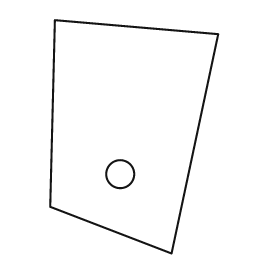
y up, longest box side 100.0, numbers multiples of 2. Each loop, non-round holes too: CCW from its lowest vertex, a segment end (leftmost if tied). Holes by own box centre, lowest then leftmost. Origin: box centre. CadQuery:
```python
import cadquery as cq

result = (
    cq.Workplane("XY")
    .moveTo(16.0, -50.0)
    .lineTo(36.0, 44.0)
    .lineTo(-34.0, 50.0)
    .lineTo(-36.0, -30.0)
    .close()
    .moveTo(-6.0, -16.0)
    .circle(6.0)
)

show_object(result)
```